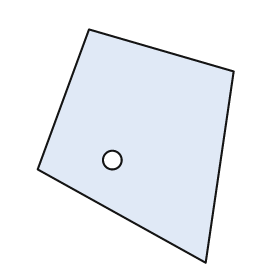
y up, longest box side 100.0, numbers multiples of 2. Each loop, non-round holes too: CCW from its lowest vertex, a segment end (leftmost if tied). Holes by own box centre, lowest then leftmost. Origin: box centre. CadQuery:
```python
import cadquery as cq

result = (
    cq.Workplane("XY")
    .moveTo(30.0, -50.0)
    .lineTo(42.0, 32.0)
    .lineTo(-20.0, 50.0)
    .lineTo(-42.0, -10.0)
    .close()
    .moveTo(-10.0, -6.0)
    .circle(4.0)
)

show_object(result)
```